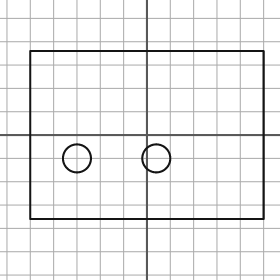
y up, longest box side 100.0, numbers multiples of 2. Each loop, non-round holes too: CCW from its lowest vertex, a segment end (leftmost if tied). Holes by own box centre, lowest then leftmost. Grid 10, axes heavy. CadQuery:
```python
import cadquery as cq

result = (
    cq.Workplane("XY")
    .moveTo(-50.0, -36.0)
    .lineTo(50.0, -36.0)
    .lineTo(50.0, 36.0)
    .lineTo(-50.0, 36.0)
    .close()
    .moveTo(-30.0, -10.0)
    .circle(6.0)
    .moveTo(4.0, -10.0)
    .circle(6.0)
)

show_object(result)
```